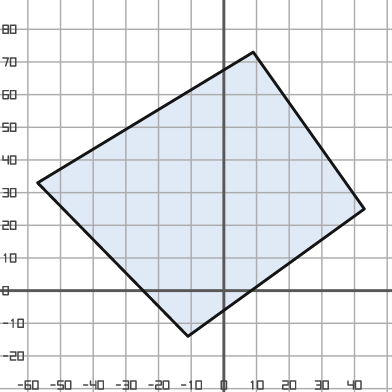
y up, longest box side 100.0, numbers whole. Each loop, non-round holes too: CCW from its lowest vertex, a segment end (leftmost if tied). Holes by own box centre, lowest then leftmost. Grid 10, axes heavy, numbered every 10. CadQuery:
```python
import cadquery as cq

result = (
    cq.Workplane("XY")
    .moveTo(-11.0, -14.0)
    .lineTo(43.0, 25.0)
    .lineTo(9.0, 73.0)
    .lineTo(-57.0, 33.0)
    .close()
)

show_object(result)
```